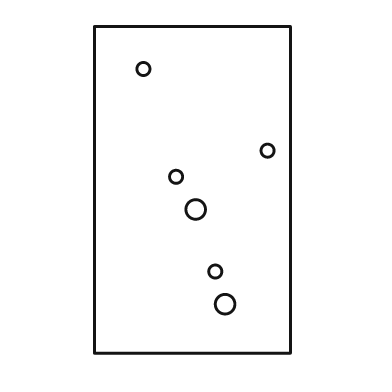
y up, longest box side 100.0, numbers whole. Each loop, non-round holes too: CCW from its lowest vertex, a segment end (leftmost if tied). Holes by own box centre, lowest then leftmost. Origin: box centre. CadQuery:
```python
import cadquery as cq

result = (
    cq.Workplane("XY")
    .moveTo(-30.0, -50.0)
    .lineTo(30.0, -50.0)
    .lineTo(30.0, 50.0)
    .lineTo(-30.0, 50.0)
    .close()
    .moveTo(10.0, -35.0)
    .circle(3.0)
    .moveTo(7.0, -25.0)
    .circle(2.0)
    .moveTo(1.0, -6.0)
    .circle(3.0)
    .moveTo(-5.0, 4.0)
    .circle(2.0)
    .moveTo(23.0, 12.0)
    .circle(2.0)
    .moveTo(-15.0, 37.0)
    .circle(2.0)
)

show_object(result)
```